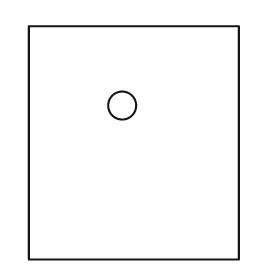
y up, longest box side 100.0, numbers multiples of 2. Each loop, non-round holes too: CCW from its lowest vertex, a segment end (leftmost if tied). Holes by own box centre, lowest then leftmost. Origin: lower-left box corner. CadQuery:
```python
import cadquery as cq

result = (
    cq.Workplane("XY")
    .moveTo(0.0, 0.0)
    .lineTo(90.0, 0.0)
    .lineTo(90.0, 100.0)
    .lineTo(0.0, 100.0)
    .close()
    .moveTo(40.0, 66.0)
    .circle(6.0)
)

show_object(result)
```